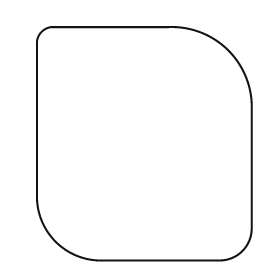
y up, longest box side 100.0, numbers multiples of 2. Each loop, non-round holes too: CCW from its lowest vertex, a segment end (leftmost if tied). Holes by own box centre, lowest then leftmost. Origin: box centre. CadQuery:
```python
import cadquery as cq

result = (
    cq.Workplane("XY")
    .moveTo(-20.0, -50.0)
    .lineTo(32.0, -50.0)
    .threePointArc((42.0, -46.0), (46.0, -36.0))
    .lineTo(46.0, 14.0)
    .threePointArc((36.0, 40.0), (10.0, 50.0))
    .lineTo(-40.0, 50.0)
    .threePointArc((-44.0, 48.0), (-46.0, 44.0))
    .lineTo(-46.0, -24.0)
    .threePointArc((-38.0, -42.0), (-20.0, -50.0))
    .close()
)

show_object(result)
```